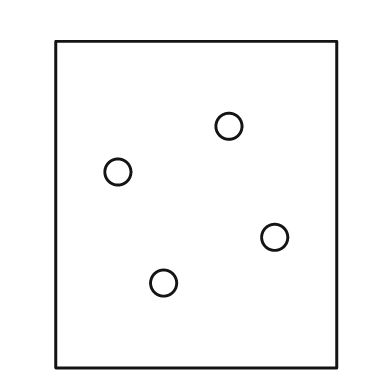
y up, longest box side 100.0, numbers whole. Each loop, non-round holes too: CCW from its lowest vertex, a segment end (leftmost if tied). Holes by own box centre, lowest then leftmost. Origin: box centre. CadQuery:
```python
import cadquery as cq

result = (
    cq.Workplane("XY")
    .moveTo(-43.0, -50.0)
    .lineTo(43.0, -50.0)
    .lineTo(43.0, 50.0)
    .lineTo(-43.0, 50.0)
    .close()
    .moveTo(-10.0, -24.0)
    .circle(4.0)
    .moveTo(24.0, -10.0)
    .circle(4.0)
    .moveTo(-24.0, 10.0)
    .circle(4.0)
    .moveTo(10.0, 24.0)
    .circle(4.0)
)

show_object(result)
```